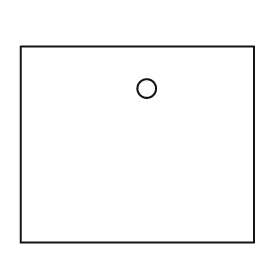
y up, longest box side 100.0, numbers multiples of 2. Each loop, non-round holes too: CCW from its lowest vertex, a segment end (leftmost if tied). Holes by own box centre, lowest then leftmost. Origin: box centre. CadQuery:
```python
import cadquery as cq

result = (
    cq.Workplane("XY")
    .moveTo(-50.0, -42.0)
    .lineTo(50.0, -42.0)
    .lineTo(50.0, 42.0)
    .lineTo(-50.0, 42.0)
    .close()
    .moveTo(4.0, 24.0)
    .circle(4.0)
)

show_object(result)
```